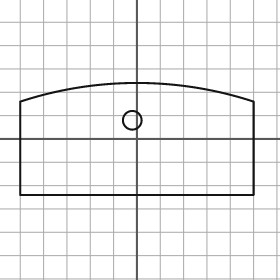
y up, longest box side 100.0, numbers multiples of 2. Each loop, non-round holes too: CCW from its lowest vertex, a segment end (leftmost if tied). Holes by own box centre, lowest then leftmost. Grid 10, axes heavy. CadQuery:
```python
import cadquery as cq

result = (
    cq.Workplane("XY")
    .moveTo(-50.0, -24.0)
    .lineTo(50.0, -24.0)
    .lineTo(50.0, 16.0)
    .threePointArc((0.0, 24.0), (-50.0, 16.0))
    .close()
    .moveTo(-2.0, 8.0)
    .circle(4.0)
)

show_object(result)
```